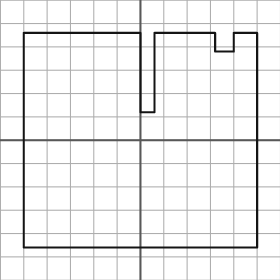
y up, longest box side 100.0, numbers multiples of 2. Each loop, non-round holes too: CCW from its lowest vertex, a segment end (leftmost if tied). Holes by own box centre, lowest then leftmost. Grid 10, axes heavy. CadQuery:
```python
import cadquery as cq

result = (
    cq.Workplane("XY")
    .moveTo(-50.0, -46.0)
    .lineTo(50.0, -46.0)
    .lineTo(50.0, 46.0)
    .lineTo(40.0, 46.0)
    .lineTo(40.0, 38.0)
    .lineTo(32.0, 38.0)
    .lineTo(32.0, 46.0)
    .lineTo(6.0, 46.0)
    .lineTo(6.0, 12.0)
    .lineTo(0.0, 12.0)
    .lineTo(0.0, 46.0)
    .lineTo(-50.0, 46.0)
    .close()
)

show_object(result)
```